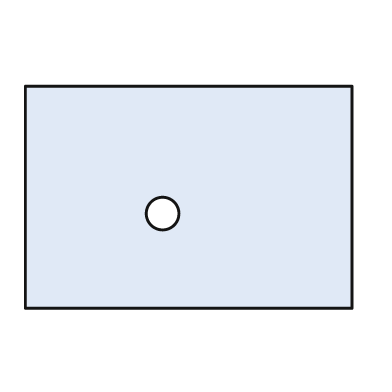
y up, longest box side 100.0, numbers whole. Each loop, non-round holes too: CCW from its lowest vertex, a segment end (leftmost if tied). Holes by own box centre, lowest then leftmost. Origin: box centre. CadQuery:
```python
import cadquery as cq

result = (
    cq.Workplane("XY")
    .moveTo(-50.0, -34.0)
    .lineTo(50.0, -34.0)
    .lineTo(50.0, 34.0)
    .lineTo(-50.0, 34.0)
    .close()
    .moveTo(-8.0, -5.0)
    .circle(5.0)
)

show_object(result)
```